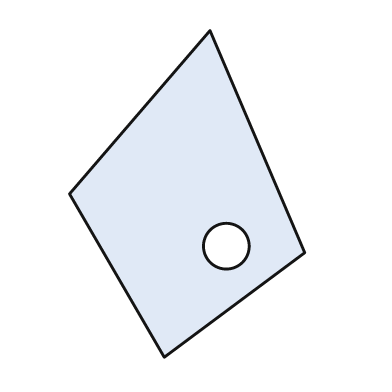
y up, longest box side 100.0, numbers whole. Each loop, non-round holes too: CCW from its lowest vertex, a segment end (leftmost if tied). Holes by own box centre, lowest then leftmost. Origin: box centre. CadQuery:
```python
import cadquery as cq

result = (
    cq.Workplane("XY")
    .moveTo(-7.0, -50.0)
    .lineTo(36.0, -18.0)
    .lineTo(7.0, 50.0)
    .lineTo(-36.0, 0.0)
    .close()
    .moveTo(12.0, -16.0)
    .circle(7.0)
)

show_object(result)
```